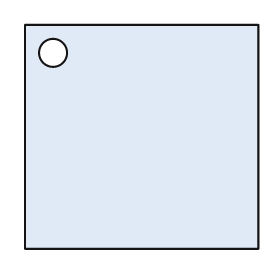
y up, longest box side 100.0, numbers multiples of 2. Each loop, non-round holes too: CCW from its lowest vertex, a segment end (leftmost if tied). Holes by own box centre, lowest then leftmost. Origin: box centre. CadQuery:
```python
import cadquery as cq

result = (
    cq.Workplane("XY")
    .moveTo(-50.0, -48.0)
    .lineTo(50.0, -48.0)
    .lineTo(50.0, 48.0)
    .lineTo(-50.0, 48.0)
    .close()
    .moveTo(-38.0, 36.0)
    .circle(6.0)
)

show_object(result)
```